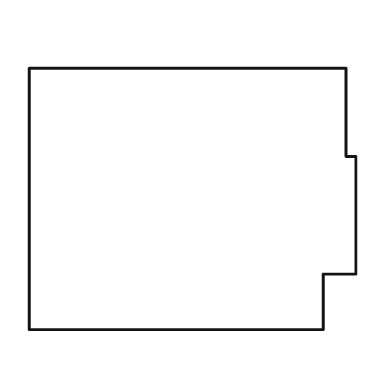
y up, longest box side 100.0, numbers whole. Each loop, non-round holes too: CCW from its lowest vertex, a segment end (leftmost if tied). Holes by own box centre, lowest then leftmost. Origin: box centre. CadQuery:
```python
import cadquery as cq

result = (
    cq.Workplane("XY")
    .moveTo(-50.0, -40.0)
    .lineTo(40.0, -40.0)
    .lineTo(40.0, -23.0)
    .lineTo(50.0, -23.0)
    .lineTo(50.0, 13.0)
    .lineTo(47.0, 13.0)
    .lineTo(47.0, 40.0)
    .lineTo(-50.0, 40.0)
    .close()
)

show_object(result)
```